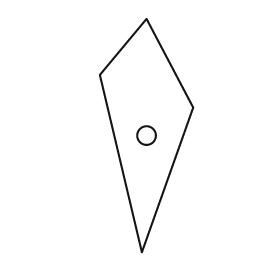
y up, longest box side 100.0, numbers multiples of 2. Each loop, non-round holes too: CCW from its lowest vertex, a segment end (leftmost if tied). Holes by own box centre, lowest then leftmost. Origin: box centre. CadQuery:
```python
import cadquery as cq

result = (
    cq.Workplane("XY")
    .moveTo(-2.0, -50.0)
    .lineTo(20.0, 12.0)
    .lineTo(0.0, 50.0)
    .lineTo(-20.0, 26.0)
    .close()
    .moveTo(0.0, 0.0)
    .circle(4.0)
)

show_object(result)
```